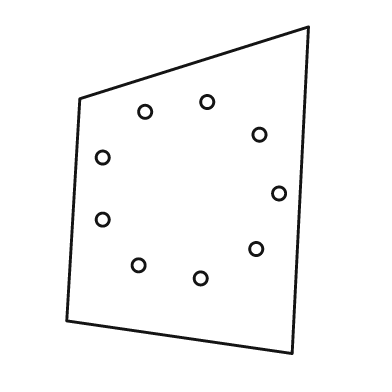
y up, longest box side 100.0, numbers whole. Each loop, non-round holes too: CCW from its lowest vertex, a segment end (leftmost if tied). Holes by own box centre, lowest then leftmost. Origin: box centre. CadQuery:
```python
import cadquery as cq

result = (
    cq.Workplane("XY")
    .moveTo(32.0, -50.0)
    .lineTo(37.0, 50.0)
    .lineTo(-33.0, 28.0)
    .lineTo(-37.0, -40.0)
    .close()
    .moveTo(4.0, -27.0)
    .circle(2.0)
    .moveTo(-15.0, -23.0)
    .circle(2.0)
    .moveTo(21.0, -18.0)
    .circle(2.0)
    .moveTo(-26.0, -9.0)
    .circle(2.0)
    .moveTo(28.0, -1.0)
    .circle(2.0)
    .moveTo(-26.0, 10.0)
    .circle(2.0)
    .moveTo(22.0, 17.0)
    .circle(2.0)
    .moveTo(-13.0, 24.0)
    .circle(2.0)
    .moveTo(6.0, 27.0)
    .circle(2.0)
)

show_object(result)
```